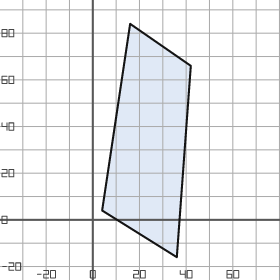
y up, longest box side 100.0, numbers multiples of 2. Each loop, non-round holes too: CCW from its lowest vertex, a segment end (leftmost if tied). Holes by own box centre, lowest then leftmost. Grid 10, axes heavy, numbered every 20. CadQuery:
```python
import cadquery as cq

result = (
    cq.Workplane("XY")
    .moveTo(36.0, -16.0)
    .lineTo(42.0, 66.0)
    .lineTo(16.0, 84.0)
    .lineTo(4.0, 4.0)
    .close()
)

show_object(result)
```